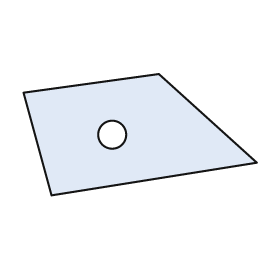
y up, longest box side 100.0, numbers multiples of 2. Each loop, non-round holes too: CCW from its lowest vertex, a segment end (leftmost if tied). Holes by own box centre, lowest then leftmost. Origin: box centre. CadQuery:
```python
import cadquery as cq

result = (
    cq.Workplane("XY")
    .moveTo(-38.0, -26.0)
    .lineTo(50.0, -12.0)
    .lineTo(8.0, 26.0)
    .lineTo(-50.0, 18.0)
    .close()
    .moveTo(-12.0, 0.0)
    .circle(6.0)
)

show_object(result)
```